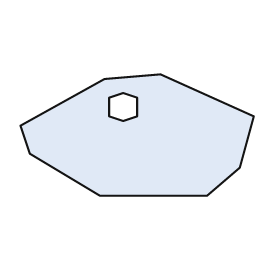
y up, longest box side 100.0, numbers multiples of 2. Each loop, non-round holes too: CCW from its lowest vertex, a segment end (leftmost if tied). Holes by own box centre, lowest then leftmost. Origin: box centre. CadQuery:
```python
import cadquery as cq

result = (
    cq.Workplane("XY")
    .moveTo(-16.0, -26.0)
    .lineTo(30.0, -26.0)
    .lineTo(44.0, -14.0)
    .lineTo(50.0, 8.0)
    .lineTo(10.0, 26.0)
    .lineTo(-14.0, 24.0)
    .lineTo(-50.0, 4.0)
    .lineTo(-46.0, -8.0)
    .close()
    .moveTo(-6.0, 6.0)
    .lineTo(0.0, 8.0)
    .lineTo(0.0, 16.0)
    .lineTo(-6.0, 18.0)
    .lineTo(-12.0, 16.0)
    .lineTo(-12.0, 8.0)
    .close()
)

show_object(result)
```